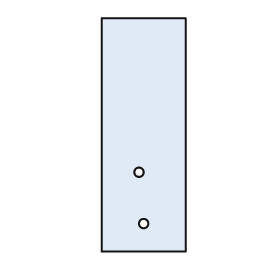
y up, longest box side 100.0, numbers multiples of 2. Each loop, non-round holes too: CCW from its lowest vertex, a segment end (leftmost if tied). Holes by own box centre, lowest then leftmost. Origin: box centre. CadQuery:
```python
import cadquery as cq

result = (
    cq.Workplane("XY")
    .moveTo(-18.0, -50.0)
    .lineTo(18.0, -50.0)
    .lineTo(18.0, 50.0)
    .lineTo(-18.0, 50.0)
    .close()
    .moveTo(0.0, -38.0)
    .circle(2.0)
    .moveTo(-2.0, -16.0)
    .circle(2.0)
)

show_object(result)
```